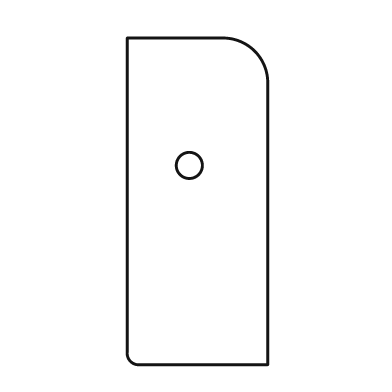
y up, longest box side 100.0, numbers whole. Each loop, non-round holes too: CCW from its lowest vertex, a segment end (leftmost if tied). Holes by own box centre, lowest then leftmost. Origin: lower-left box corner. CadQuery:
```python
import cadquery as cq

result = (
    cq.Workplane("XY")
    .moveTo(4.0, 0.0)
    .lineTo(43.0, 0.0)
    .lineTo(43.0, 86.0)
    .threePointArc((39.0, 96.0), (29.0, 100.0))
    .lineTo(0.0, 100.0)
    .lineTo(0.0, 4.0)
    .threePointArc((1.0, 1.0), (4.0, 0.0))
    .close()
    .moveTo(19.0, 61.0)
    .circle(4.0)
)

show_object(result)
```